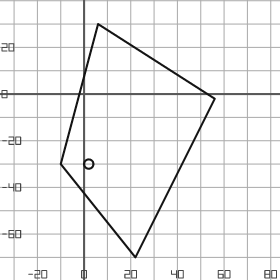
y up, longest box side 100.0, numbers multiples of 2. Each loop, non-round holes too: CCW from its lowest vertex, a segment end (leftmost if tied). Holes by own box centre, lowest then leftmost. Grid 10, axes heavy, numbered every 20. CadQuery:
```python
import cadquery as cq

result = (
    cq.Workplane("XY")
    .moveTo(22.0, -70.0)
    .lineTo(56.0, -2.0)
    .lineTo(6.0, 30.0)
    .lineTo(-10.0, -30.0)
    .close()
    .moveTo(2.0, -30.0)
    .circle(2.0)
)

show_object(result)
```